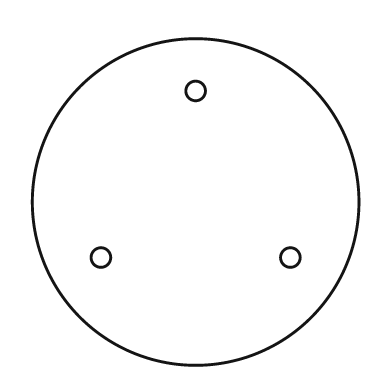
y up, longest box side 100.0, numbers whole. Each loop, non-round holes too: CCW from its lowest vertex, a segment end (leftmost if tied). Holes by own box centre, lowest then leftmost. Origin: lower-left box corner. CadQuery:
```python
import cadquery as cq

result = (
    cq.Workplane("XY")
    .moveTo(50.0, 50.0)
    .circle(50.0)
    .moveTo(21.0, 33.0)
    .circle(3.0)
    .moveTo(79.0, 33.0)
    .circle(3.0)
    .moveTo(50.0, 84.0)
    .circle(3.0)
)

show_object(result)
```